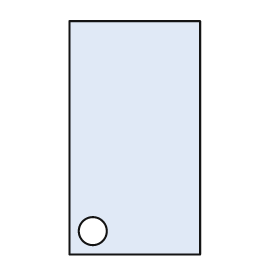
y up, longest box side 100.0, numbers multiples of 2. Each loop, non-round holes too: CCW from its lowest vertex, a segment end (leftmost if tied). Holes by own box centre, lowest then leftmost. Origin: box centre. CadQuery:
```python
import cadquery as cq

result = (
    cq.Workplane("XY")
    .moveTo(-28.0, -50.0)
    .lineTo(28.0, -50.0)
    .lineTo(28.0, 50.0)
    .lineTo(-28.0, 50.0)
    .close()
    .moveTo(-18.0, -40.0)
    .circle(6.0)
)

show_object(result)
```